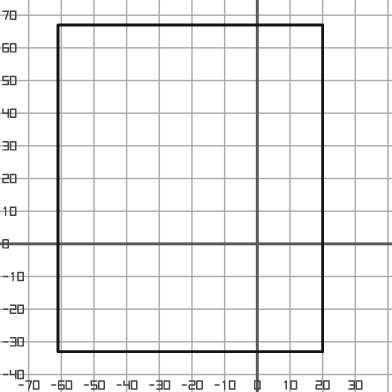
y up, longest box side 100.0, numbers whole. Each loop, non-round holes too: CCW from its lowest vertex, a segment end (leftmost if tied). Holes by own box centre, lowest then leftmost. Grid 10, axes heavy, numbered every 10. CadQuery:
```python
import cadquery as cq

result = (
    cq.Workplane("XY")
    .moveTo(-61.0, -33.0)
    .lineTo(20.0, -33.0)
    .lineTo(20.0, 67.0)
    .lineTo(-61.0, 67.0)
    .close()
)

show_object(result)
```